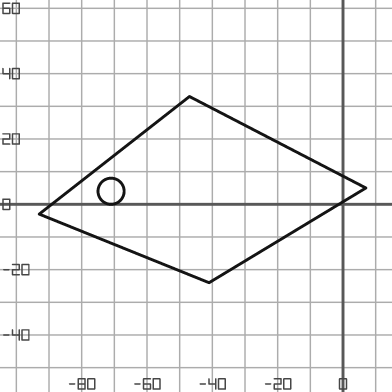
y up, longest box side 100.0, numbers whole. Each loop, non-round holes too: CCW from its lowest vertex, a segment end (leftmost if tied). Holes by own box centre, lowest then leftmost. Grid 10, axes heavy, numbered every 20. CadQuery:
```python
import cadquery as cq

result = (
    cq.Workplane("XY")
    .moveTo(-41.0, -24.0)
    .lineTo(7.0, 5.0)
    .lineTo(-47.0, 33.0)
    .lineTo(-93.0, -3.0)
    .close()
    .moveTo(-71.0, 4.0)
    .circle(4.0)
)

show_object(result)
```